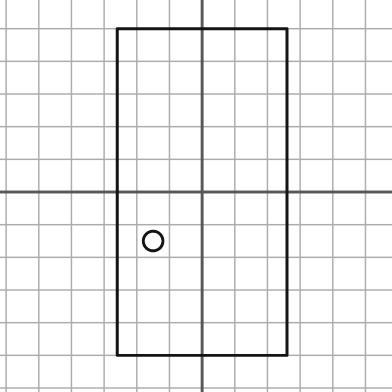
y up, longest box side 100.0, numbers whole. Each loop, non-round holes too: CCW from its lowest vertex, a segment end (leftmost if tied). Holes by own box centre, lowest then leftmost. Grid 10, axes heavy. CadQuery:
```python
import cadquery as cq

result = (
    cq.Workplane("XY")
    .moveTo(-26.0, -50.0)
    .lineTo(26.0, -50.0)
    .lineTo(26.0, 50.0)
    .lineTo(-26.0, 50.0)
    .close()
    .moveTo(-15.0, -15.0)
    .circle(3.0)
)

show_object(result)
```